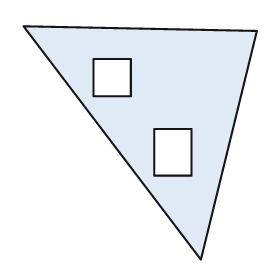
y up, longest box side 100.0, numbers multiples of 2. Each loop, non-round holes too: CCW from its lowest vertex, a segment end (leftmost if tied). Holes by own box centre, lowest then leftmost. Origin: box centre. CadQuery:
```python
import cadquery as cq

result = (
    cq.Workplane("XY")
    .moveTo(26.0, -50.0)
    .lineTo(50.0, 48.0)
    .lineTo(-50.0, 50.0)
    .close()
    .moveTo(6.0, -14.0)
    .lineTo(22.0, -14.0)
    .lineTo(22.0, 6.0)
    .lineTo(6.0, 6.0)
    .close()
    .moveTo(-20.0, 20.0)
    .lineTo(-4.0, 20.0)
    .lineTo(-4.0, 36.0)
    .lineTo(-20.0, 36.0)
    .close()
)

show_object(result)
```